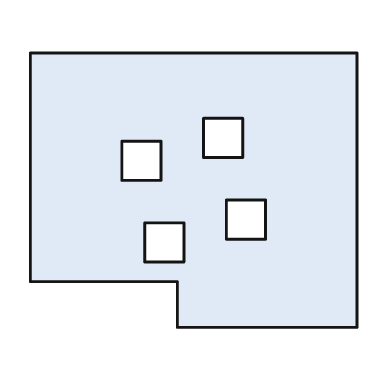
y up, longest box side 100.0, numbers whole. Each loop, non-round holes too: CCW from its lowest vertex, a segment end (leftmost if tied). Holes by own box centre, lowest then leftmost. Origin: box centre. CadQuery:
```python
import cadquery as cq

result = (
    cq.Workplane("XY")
    .moveTo(-5.0, -42.0)
    .lineTo(50.0, -42.0)
    .lineTo(50.0, 42.0)
    .lineTo(-50.0, 42.0)
    .lineTo(-50.0, -28.0)
    .lineTo(-5.0, -28.0)
    .close()
    .moveTo(-15.0, -22.0)
    .lineTo(-3.0, -22.0)
    .lineTo(-3.0, -10.0)
    .lineTo(-15.0, -10.0)
    .close()
    .moveTo(10.0, -15.0)
    .lineTo(22.0, -15.0)
    .lineTo(22.0, -3.0)
    .lineTo(10.0, -3.0)
    .close()
    .moveTo(-22.0, 3.0)
    .lineTo(-10.0, 3.0)
    .lineTo(-10.0, 15.0)
    .lineTo(-22.0, 15.0)
    .close()
    .moveTo(3.0, 10.0)
    .lineTo(15.0, 10.0)
    .lineTo(15.0, 22.0)
    .lineTo(3.0, 22.0)
    .close()
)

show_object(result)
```